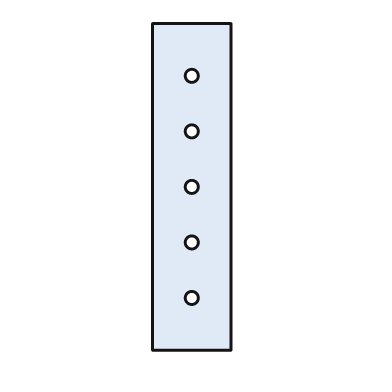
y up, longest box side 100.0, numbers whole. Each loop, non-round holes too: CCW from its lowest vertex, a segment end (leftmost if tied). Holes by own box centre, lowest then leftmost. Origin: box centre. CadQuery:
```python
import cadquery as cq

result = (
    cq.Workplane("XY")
    .moveTo(-12.0, -50.0)
    .lineTo(12.0, -50.0)
    .lineTo(12.0, 50.0)
    .lineTo(-12.0, 50.0)
    .close()
    .moveTo(0.0, -34.0)
    .circle(2.0)
    .moveTo(0.0, -17.0)
    .circle(2.0)
    .moveTo(0.0, 0.0)
    .circle(2.0)
    .moveTo(0.0, 17.0)
    .circle(2.0)
    .moveTo(0.0, 34.0)
    .circle(2.0)
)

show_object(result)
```